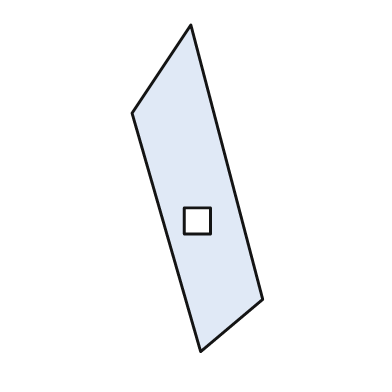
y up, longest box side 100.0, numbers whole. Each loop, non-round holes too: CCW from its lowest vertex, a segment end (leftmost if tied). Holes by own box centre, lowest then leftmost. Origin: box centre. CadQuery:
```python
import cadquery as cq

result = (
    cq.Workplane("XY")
    .moveTo(1.0, -50.0)
    .lineTo(20.0, -34.0)
    .lineTo(-2.0, 50.0)
    .lineTo(-20.0, 23.0)
    .close()
    .moveTo(-4.0, -14.0)
    .lineTo(4.0, -14.0)
    .lineTo(4.0, -6.0)
    .lineTo(-4.0, -6.0)
    .close()
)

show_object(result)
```